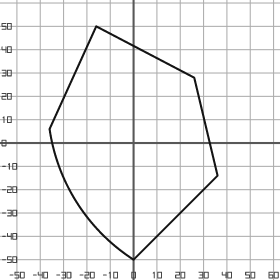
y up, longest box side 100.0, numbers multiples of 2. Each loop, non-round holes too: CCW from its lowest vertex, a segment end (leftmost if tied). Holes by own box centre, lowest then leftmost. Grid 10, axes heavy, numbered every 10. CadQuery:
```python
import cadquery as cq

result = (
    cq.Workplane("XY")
    .moveTo(0.0, -50.0)
    .lineTo(36.0, -14.0)
    .lineTo(26.0, 28.0)
    .lineTo(-16.0, 50.0)
    .lineTo(-36.0, 6.0)
    .threePointArc((-24.0, -26.0), (0.0, -50.0))
    .close()
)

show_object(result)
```